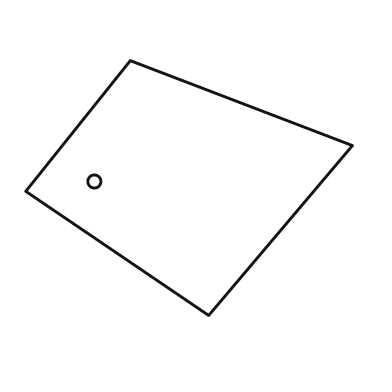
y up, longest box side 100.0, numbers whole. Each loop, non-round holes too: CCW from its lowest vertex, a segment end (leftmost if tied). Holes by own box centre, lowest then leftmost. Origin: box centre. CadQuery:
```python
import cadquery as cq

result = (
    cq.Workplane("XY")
    .moveTo(6.0, -39.0)
    .lineTo(50.0, 13.0)
    .lineTo(-18.0, 39.0)
    .lineTo(-50.0, -1.0)
    .close()
    .moveTo(-29.0, 2.0)
    .circle(2.0)
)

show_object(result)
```